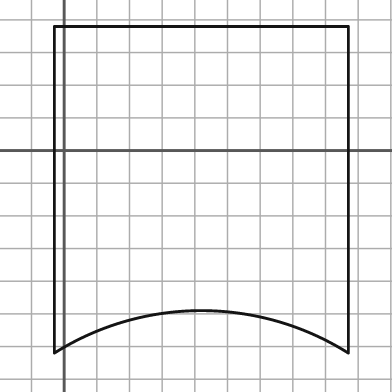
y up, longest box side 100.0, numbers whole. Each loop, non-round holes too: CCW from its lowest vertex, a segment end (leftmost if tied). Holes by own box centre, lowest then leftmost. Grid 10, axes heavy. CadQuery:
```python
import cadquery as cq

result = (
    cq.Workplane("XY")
    .moveTo(-3.0, -62.0)
    .threePointArc((42.0, -49.0), (87.0, -62.0))
    .lineTo(87.0, 38.0)
    .lineTo(-3.0, 38.0)
    .close()
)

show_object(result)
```